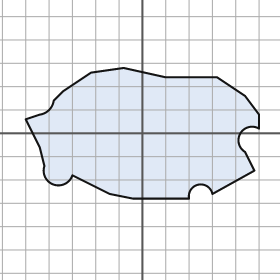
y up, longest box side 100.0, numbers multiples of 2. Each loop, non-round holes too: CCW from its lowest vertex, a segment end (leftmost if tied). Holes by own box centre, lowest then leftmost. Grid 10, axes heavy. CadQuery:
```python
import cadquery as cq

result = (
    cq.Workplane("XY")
    .moveTo(-4.0, -28.0)
    .lineTo(20.0, -28.0)
    .threePointArc((24.0, -22.0), (30.0, -26.0))
    .lineTo(48.0, -16.0)
    .lineTo(44.0, -8.0)
    .threePointArc((42.0, 0.0), (50.0, 2.0))
    .lineTo(50.0, 8.0)
    .lineTo(44.0, 16.0)
    .lineTo(32.0, 24.0)
    .lineTo(10.0, 24.0)
    .lineTo(-8.0, 28.0)
    .lineTo(-22.0, 26.0)
    .lineTo(-34.0, 18.0)
    .lineTo(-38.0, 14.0)
    .threePointArc((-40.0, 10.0), (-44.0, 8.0))
    .lineTo(-50.0, 6.0)
    .lineTo(-44.0, -6.0)
    .lineTo(-42.0, -14.0)
    .threePointArc((-38.0, -22.0), (-30.0, -18.0))
    .lineTo(-14.0, -26.0)
    .close()
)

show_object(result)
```